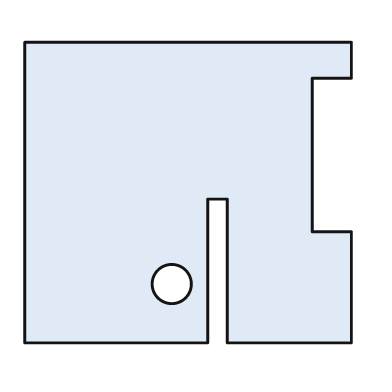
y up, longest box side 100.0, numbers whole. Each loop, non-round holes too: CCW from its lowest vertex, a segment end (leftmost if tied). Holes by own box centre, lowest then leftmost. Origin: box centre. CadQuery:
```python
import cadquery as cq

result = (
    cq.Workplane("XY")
    .moveTo(-50.0, -46.0)
    .lineTo(6.0, -46.0)
    .lineTo(6.0, -2.0)
    .lineTo(12.0, -2.0)
    .lineTo(12.0, -46.0)
    .lineTo(50.0, -46.0)
    .lineTo(50.0, -12.0)
    .lineTo(38.0, -12.0)
    .lineTo(38.0, 35.0)
    .lineTo(50.0, 35.0)
    .lineTo(50.0, 46.0)
    .lineTo(-50.0, 46.0)
    .close()
    .moveTo(-5.0, -28.0)
    .circle(6.0)
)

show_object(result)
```